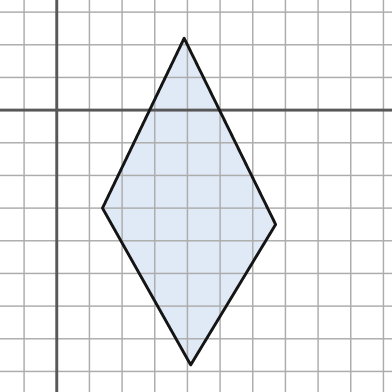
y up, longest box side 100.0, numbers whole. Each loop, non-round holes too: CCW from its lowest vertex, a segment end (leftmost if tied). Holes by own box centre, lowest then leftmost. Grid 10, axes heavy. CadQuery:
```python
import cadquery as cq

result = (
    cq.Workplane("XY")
    .moveTo(41.0, -78.0)
    .lineTo(67.0, -35.0)
    .lineTo(39.0, 22.0)
    .lineTo(14.0, -30.0)
    .close()
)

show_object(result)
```